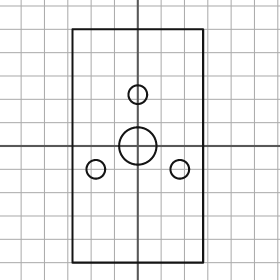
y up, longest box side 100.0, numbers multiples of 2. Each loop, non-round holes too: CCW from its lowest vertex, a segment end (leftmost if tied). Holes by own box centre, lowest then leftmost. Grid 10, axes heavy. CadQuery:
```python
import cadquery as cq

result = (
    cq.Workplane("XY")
    .moveTo(-28.0, -50.0)
    .lineTo(28.0, -50.0)
    .lineTo(28.0, 50.0)
    .lineTo(-28.0, 50.0)
    .close()
    .moveTo(-18.0, -10.0)
    .circle(4.0)
    .moveTo(18.0, -10.0)
    .circle(4.0)
    .moveTo(0.0, 0.0)
    .circle(8.0)
    .moveTo(0.0, 22.0)
    .circle(4.0)
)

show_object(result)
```